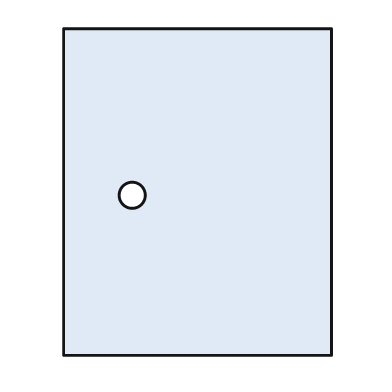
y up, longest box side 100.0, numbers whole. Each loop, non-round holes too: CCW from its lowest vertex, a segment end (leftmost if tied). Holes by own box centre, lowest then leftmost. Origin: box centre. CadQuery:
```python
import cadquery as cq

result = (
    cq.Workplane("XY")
    .moveTo(-41.0, -50.0)
    .lineTo(41.0, -50.0)
    .lineTo(41.0, 50.0)
    .lineTo(-41.0, 50.0)
    .close()
    .moveTo(-20.0, -1.0)
    .circle(4.0)
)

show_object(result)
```